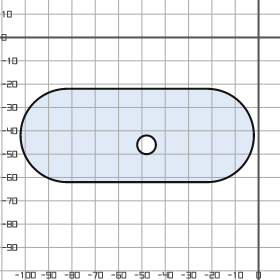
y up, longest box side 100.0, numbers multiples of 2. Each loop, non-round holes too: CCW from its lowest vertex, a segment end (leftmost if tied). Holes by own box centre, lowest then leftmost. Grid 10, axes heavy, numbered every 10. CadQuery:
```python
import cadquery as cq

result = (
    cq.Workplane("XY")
    .moveTo(-82.0, -62.0)
    .lineTo(-22.0, -62.0)
    .threePointArc((-2.0, -42.0), (-22.0, -22.0))
    .lineTo(-82.0, -22.0)
    .threePointArc((-102.0, -42.0), (-82.0, -62.0))
    .close()
    .moveTo(-48.0, -46.0)
    .circle(4.0)
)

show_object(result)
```